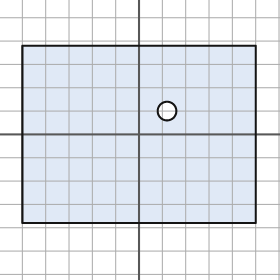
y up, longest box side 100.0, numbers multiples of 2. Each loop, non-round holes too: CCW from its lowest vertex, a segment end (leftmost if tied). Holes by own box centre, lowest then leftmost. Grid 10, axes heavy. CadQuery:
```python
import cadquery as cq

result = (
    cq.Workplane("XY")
    .moveTo(-50.0, -38.0)
    .lineTo(50.0, -38.0)
    .lineTo(50.0, 38.0)
    .lineTo(-50.0, 38.0)
    .close()
    .moveTo(12.0, 10.0)
    .circle(4.0)
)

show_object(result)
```